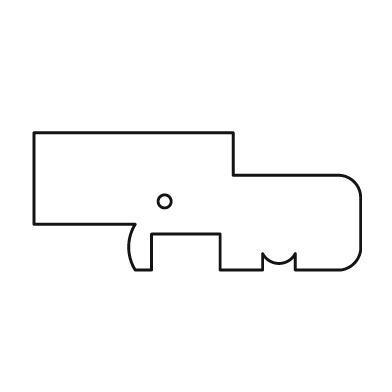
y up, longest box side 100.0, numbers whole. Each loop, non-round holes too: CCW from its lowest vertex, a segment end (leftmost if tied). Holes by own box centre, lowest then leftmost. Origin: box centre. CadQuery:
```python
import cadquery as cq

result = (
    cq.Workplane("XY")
    .moveTo(-19.0, -21.0)
    .lineTo(-14.0, -21.0)
    .lineTo(-14.0, -10.0)
    .lineTo(7.0, -10.0)
    .lineTo(7.0, -21.0)
    .lineTo(20.0, -21.0)
    .lineTo(20.0, -16.0)
    .threePointArc((25.0, -19.0), (30.0, -16.0))
    .lineTo(30.0, -21.0)
    .lineTo(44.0, -21.0)
    .threePointArc((48.0, -19.0), (50.0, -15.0))
    .lineTo(50.0, 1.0)
    .threePointArc((48.0, 6.0), (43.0, 8.0))
    .lineTo(11.0, 8.0)
    .lineTo(11.0, 21.0)
    .lineTo(-50.0, 21.0)
    .lineTo(-50.0, -7.0)
    .lineTo(-19.0, -7.0)
    .threePointArc((-21.0, -14.0), (-19.0, -21.0))
    .close()
    .moveTo(-10.0, 0.0)
    .circle(2.0)
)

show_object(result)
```